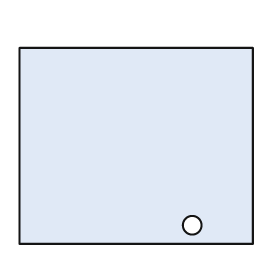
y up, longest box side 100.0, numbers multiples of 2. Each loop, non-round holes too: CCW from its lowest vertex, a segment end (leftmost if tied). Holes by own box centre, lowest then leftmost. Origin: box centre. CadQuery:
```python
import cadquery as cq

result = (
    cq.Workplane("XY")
    .moveTo(-50.0, -42.0)
    .lineTo(50.0, -42.0)
    .lineTo(50.0, 42.0)
    .lineTo(-50.0, 42.0)
    .close()
    .moveTo(24.0, -34.0)
    .circle(4.0)
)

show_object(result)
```